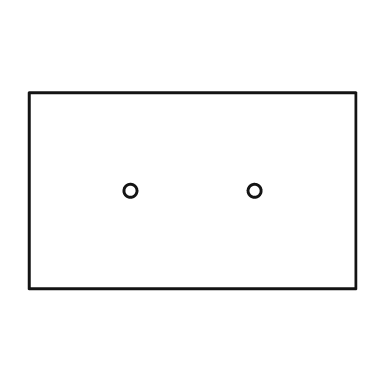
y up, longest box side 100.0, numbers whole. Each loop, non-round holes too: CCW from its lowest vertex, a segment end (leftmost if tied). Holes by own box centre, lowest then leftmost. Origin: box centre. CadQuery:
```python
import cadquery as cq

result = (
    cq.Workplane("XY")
    .moveTo(-50.0, -30.0)
    .lineTo(50.0, -30.0)
    .lineTo(50.0, 30.0)
    .lineTo(-50.0, 30.0)
    .close()
    .moveTo(-19.0, 0.0)
    .circle(2.0)
    .moveTo(19.0, 0.0)
    .circle(2.0)
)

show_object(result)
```